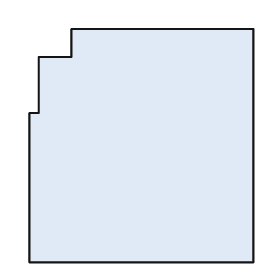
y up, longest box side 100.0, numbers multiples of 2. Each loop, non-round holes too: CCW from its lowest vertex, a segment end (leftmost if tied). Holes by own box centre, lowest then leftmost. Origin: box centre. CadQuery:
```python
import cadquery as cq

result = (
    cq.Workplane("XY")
    .moveTo(-48.0, -50.0)
    .lineTo(48.0, -50.0)
    .lineTo(48.0, 50.0)
    .lineTo(-30.0, 50.0)
    .lineTo(-30.0, 38.0)
    .lineTo(-44.0, 38.0)
    .lineTo(-44.0, 14.0)
    .lineTo(-48.0, 14.0)
    .close()
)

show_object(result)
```